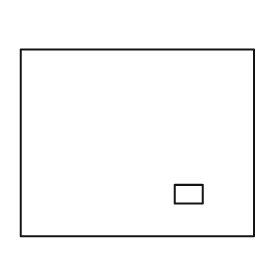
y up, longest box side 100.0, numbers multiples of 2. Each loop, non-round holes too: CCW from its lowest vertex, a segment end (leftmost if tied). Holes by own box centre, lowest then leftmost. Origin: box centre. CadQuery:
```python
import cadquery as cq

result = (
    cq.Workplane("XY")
    .moveTo(-50.0, -40.0)
    .lineTo(50.0, -40.0)
    .lineTo(50.0, 40.0)
    .lineTo(-50.0, 40.0)
    .close()
    .moveTo(16.0, -26.0)
    .lineTo(28.0, -26.0)
    .lineTo(28.0, -18.0)
    .lineTo(16.0, -18.0)
    .close()
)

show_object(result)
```